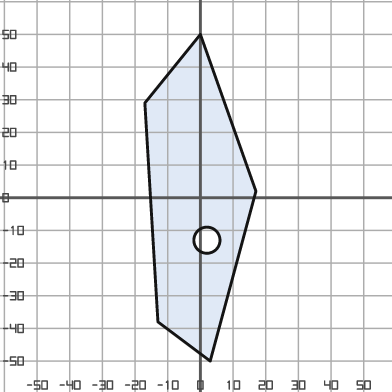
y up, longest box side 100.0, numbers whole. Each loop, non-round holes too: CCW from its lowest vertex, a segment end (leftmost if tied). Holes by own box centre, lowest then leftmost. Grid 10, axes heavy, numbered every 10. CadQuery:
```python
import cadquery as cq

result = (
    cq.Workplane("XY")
    .moveTo(3.0, -50.0)
    .lineTo(17.0, 2.0)
    .lineTo(0.0, 50.0)
    .lineTo(-17.0, 29.0)
    .lineTo(-13.0, -38.0)
    .close()
    .moveTo(2.0, -13.0)
    .circle(4.0)
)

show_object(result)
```